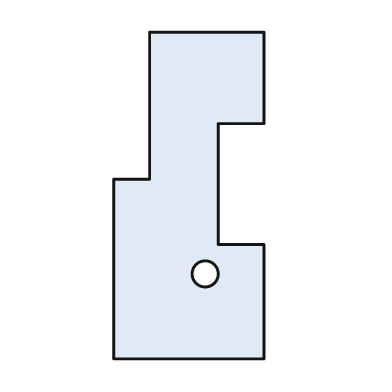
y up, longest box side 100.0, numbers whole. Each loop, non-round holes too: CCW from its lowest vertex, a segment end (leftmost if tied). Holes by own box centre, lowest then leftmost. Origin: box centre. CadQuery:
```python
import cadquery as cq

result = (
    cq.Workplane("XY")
    .moveTo(-23.0, -50.0)
    .lineTo(23.0, -50.0)
    .lineTo(23.0, -15.0)
    .lineTo(9.0, -15.0)
    .lineTo(9.0, 22.0)
    .lineTo(23.0, 22.0)
    .lineTo(23.0, 50.0)
    .lineTo(-12.0, 50.0)
    .lineTo(-12.0, 5.0)
    .lineTo(-23.0, 5.0)
    .close()
    .moveTo(5.0, -24.0)
    .circle(4.0)
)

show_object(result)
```